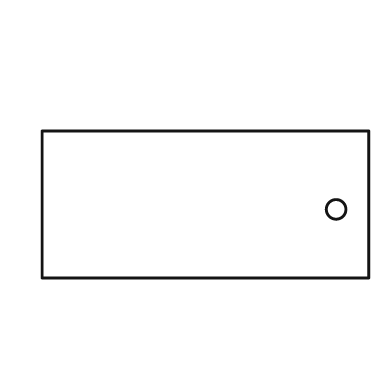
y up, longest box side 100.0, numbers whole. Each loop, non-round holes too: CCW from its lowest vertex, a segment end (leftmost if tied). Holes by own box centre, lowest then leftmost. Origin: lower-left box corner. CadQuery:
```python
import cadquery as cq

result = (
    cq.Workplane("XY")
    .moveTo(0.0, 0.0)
    .lineTo(100.0, 0.0)
    .lineTo(100.0, 45.0)
    .lineTo(0.0, 45.0)
    .close()
    .moveTo(90.0, 21.0)
    .circle(3.0)
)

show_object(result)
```